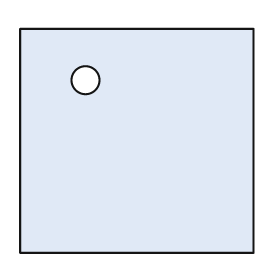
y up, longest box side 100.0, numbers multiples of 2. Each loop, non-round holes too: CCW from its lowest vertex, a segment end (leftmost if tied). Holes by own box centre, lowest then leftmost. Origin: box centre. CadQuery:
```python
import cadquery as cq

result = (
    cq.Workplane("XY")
    .moveTo(-50.0, -48.0)
    .lineTo(50.0, -48.0)
    .lineTo(50.0, 48.0)
    .lineTo(-50.0, 48.0)
    .close()
    .moveTo(-22.0, 26.0)
    .circle(6.0)
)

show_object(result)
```